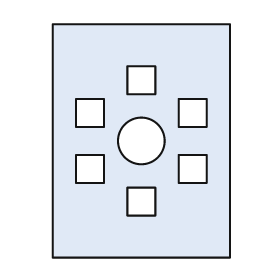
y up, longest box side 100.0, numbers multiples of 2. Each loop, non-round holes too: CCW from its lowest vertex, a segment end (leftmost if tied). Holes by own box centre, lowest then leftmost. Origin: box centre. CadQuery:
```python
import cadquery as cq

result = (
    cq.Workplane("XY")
    .moveTo(-38.0, -50.0)
    .lineTo(38.0, -50.0)
    .lineTo(38.0, 50.0)
    .lineTo(-38.0, 50.0)
    .close()
    .moveTo(-6.0, -32.0)
    .lineTo(6.0, -32.0)
    .lineTo(6.0, -20.0)
    .lineTo(-6.0, -20.0)
    .close()
    .moveTo(-28.0, -18.0)
    .lineTo(-16.0, -18.0)
    .lineTo(-16.0, -6.0)
    .lineTo(-28.0, -6.0)
    .close()
    .moveTo(16.0, -18.0)
    .lineTo(28.0, -18.0)
    .lineTo(28.0, -6.0)
    .lineTo(16.0, -6.0)
    .close()
    .moveTo(0.0, 0.0)
    .circle(10.0)
    .moveTo(-28.0, 6.0)
    .lineTo(-16.0, 6.0)
    .lineTo(-16.0, 18.0)
    .lineTo(-28.0, 18.0)
    .close()
    .moveTo(16.0, 6.0)
    .lineTo(28.0, 6.0)
    .lineTo(28.0, 18.0)
    .lineTo(16.0, 18.0)
    .close()
    .moveTo(-6.0, 20.0)
    .lineTo(6.0, 20.0)
    .lineTo(6.0, 32.0)
    .lineTo(-6.0, 32.0)
    .close()
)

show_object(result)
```